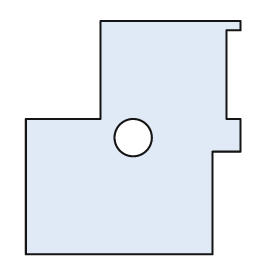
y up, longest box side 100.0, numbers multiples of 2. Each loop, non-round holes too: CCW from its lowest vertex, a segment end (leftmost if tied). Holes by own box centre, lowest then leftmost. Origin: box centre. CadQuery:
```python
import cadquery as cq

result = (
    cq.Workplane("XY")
    .moveTo(-46.0, -50.0)
    .lineTo(34.0, -50.0)
    .lineTo(34.0, -6.0)
    .lineTo(46.0, -6.0)
    .lineTo(46.0, 8.0)
    .lineTo(40.0, 8.0)
    .lineTo(40.0, 46.0)
    .lineTo(46.0, 46.0)
    .lineTo(46.0, 50.0)
    .lineTo(-14.0, 50.0)
    .lineTo(-14.0, 8.0)
    .lineTo(-46.0, 8.0)
    .close()
    .moveTo(0.0, 0.0)
    .circle(8.0)
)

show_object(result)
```